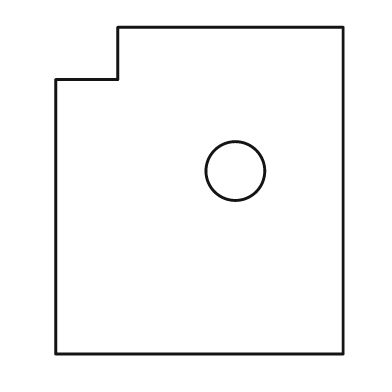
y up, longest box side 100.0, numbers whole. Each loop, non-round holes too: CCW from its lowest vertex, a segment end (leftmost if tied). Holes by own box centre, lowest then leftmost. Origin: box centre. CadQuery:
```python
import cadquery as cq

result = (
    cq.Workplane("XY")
    .moveTo(-44.0, -50.0)
    .lineTo(44.0, -50.0)
    .lineTo(44.0, 50.0)
    .lineTo(-25.0, 50.0)
    .lineTo(-25.0, 34.0)
    .lineTo(-44.0, 34.0)
    .close()
    .moveTo(11.0, 6.0)
    .circle(9.0)
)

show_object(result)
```